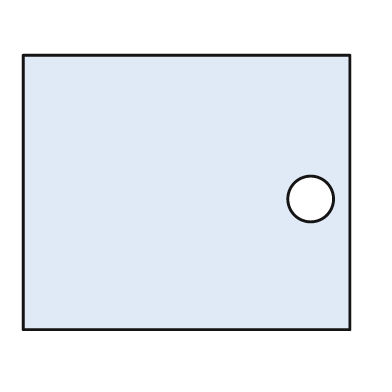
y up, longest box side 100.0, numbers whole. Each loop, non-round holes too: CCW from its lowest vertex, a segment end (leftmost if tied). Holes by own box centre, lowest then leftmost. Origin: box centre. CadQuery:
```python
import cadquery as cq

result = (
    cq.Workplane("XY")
    .moveTo(-50.0, -42.0)
    .lineTo(50.0, -42.0)
    .lineTo(50.0, 42.0)
    .lineTo(-50.0, 42.0)
    .close()
    .moveTo(38.0, -2.0)
    .circle(7.0)
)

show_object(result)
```